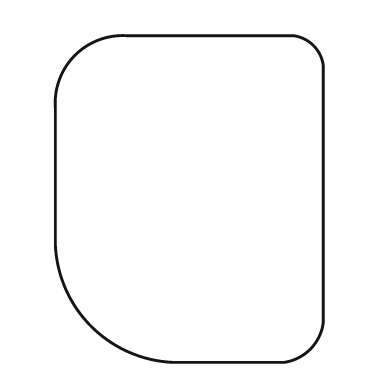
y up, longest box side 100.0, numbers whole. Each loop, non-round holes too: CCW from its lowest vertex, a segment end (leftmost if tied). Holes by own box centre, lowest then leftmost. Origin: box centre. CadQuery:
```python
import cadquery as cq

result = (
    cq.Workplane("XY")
    .moveTo(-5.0, -50.0)
    .lineTo(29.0, -50.0)
    .threePointArc((37.0, -46.0), (41.0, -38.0))
    .lineTo(41.0, 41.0)
    .threePointArc((38.0, 47.0), (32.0, 50.0))
    .lineTo(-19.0, 50.0)
    .threePointArc((-35.0, 44.0), (-41.0, 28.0))
    .lineTo(-41.0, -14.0)
    .threePointArc((-30.0, -39.0), (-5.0, -50.0))
    .close()
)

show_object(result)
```